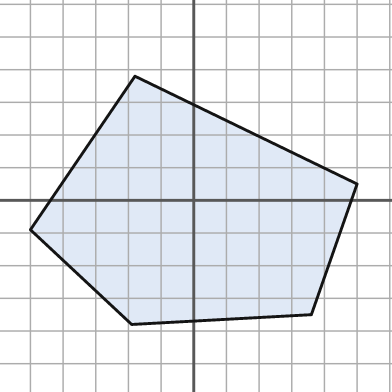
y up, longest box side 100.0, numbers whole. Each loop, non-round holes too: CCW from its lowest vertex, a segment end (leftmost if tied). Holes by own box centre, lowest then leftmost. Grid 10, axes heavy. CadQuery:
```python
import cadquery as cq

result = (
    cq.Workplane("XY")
    .moveTo(-19.0, -38.0)
    .lineTo(36.0, -35.0)
    .lineTo(50.0, 5.0)
    .lineTo(-18.0, 38.0)
    .lineTo(-50.0, -9.0)
    .close()
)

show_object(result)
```